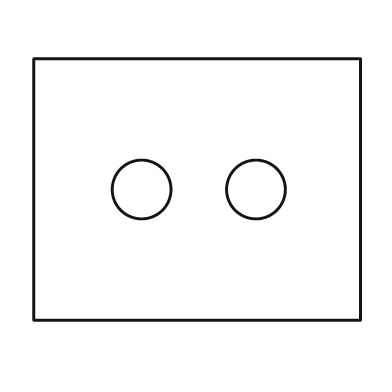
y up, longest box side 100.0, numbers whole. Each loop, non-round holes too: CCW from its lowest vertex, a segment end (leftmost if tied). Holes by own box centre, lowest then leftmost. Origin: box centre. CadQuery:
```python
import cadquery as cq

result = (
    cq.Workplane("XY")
    .moveTo(-50.0, -40.0)
    .lineTo(50.0, -40.0)
    .lineTo(50.0, 40.0)
    .lineTo(-50.0, 40.0)
    .close()
    .moveTo(-17.0, 0.0)
    .circle(9.0)
    .moveTo(18.0, 0.0)
    .circle(9.0)
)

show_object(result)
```